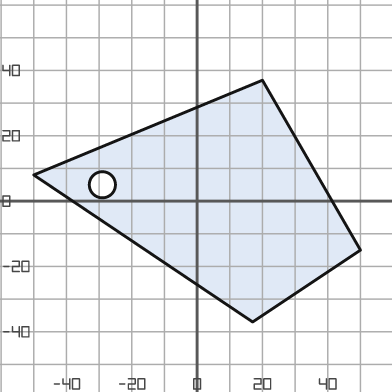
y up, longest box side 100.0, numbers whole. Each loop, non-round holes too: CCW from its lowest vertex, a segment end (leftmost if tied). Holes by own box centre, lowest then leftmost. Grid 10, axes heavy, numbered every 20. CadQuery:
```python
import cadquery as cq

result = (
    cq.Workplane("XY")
    .moveTo(17.0, -37.0)
    .lineTo(50.0, -15.0)
    .lineTo(20.0, 37.0)
    .lineTo(-50.0, 8.0)
    .close()
    .moveTo(-29.0, 5.0)
    .circle(4.0)
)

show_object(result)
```